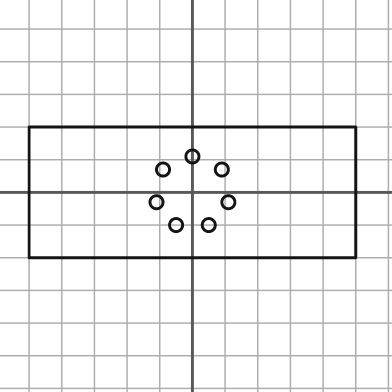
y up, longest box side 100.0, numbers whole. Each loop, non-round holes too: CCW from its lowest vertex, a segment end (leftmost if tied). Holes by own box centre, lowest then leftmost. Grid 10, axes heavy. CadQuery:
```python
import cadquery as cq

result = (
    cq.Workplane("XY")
    .moveTo(-50.0, -20.0)
    .lineTo(50.0, -20.0)
    .lineTo(50.0, 20.0)
    .lineTo(-50.0, 20.0)
    .close()
    .moveTo(-5.0, -10.0)
    .circle(2.0)
    .moveTo(5.0, -10.0)
    .circle(2.0)
    .moveTo(-11.0, -3.0)
    .circle(2.0)
    .moveTo(11.0, -3.0)
    .circle(2.0)
    .moveTo(-9.0, 7.0)
    .circle(2.0)
    .moveTo(9.0, 7.0)
    .circle(2.0)
    .moveTo(0.0, 11.0)
    .circle(2.0)
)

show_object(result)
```